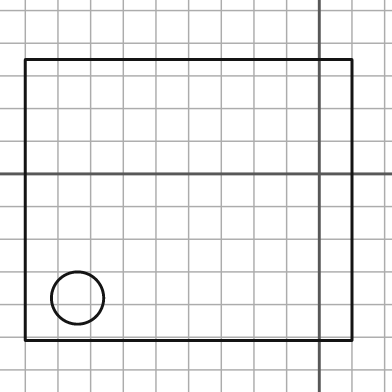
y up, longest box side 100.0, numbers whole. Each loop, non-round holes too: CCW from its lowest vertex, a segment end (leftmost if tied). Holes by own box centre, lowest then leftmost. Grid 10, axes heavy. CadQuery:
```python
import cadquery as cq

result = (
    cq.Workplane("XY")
    .moveTo(-90.0, -51.0)
    .lineTo(10.0, -51.0)
    .lineTo(10.0, 35.0)
    .lineTo(-90.0, 35.0)
    .close()
    .moveTo(-74.0, -38.0)
    .circle(8.0)
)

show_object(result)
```